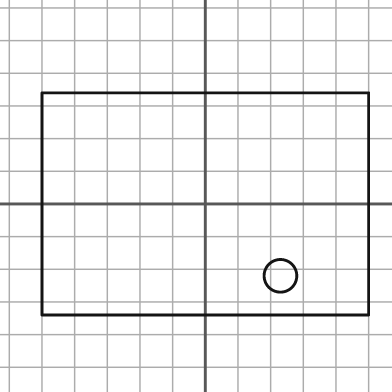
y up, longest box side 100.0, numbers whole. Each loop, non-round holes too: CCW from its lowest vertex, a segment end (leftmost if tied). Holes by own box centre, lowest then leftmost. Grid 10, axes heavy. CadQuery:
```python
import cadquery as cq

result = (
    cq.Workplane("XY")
    .moveTo(-50.0, -34.0)
    .lineTo(50.0, -34.0)
    .lineTo(50.0, 34.0)
    .lineTo(-50.0, 34.0)
    .close()
    .moveTo(23.0, -22.0)
    .circle(5.0)
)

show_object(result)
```